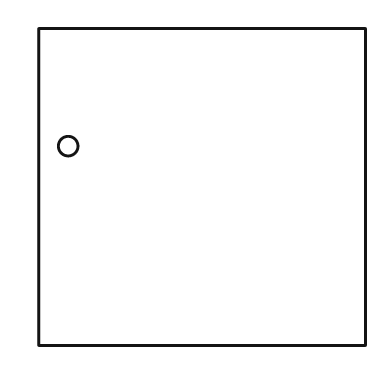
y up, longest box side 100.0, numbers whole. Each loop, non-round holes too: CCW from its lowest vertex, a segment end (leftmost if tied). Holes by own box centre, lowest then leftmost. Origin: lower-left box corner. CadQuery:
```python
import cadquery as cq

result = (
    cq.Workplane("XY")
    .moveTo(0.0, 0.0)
    .lineTo(100.0, 0.0)
    .lineTo(100.0, 97.0)
    .lineTo(0.0, 97.0)
    .close()
    .moveTo(9.0, 61.0)
    .circle(3.0)
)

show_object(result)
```